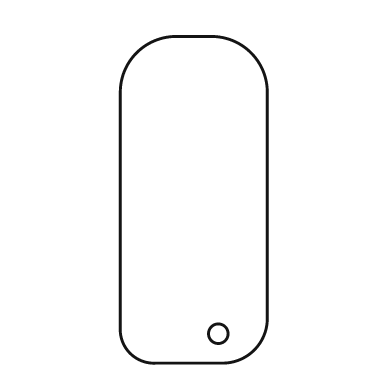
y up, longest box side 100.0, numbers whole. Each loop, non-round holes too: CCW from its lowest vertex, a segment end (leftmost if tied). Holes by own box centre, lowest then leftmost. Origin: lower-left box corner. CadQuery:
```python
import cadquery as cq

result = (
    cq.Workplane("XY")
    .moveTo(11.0, 0.0)
    .lineTo(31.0, 0.0)
    .threePointArc((41.0, 4.0), (45.0, 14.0))
    .lineTo(45.0, 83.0)
    .threePointArc((40.0, 95.0), (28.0, 100.0))
    .lineTo(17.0, 100.0)
    .threePointArc((5.0, 95.0), (0.0, 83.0))
    .lineTo(0.0, 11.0)
    .threePointArc((3.0, 3.0), (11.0, 0.0))
    .close()
    .moveTo(30.0, 9.0)
    .circle(3.0)
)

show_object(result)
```